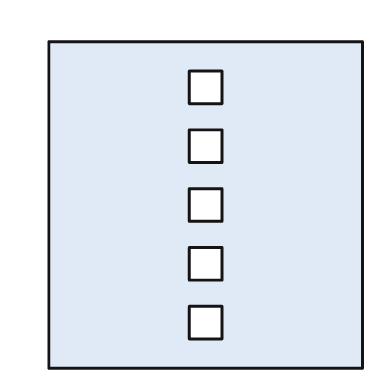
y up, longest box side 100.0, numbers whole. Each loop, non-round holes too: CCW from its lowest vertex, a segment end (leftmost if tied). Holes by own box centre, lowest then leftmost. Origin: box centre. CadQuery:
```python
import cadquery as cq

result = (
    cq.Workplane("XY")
    .moveTo(-48.0, -50.0)
    .lineTo(48.0, -50.0)
    .lineTo(48.0, 50.0)
    .lineTo(-48.0, 50.0)
    .close()
    .moveTo(-5.0, -41.0)
    .lineTo(5.0, -41.0)
    .lineTo(5.0, -31.0)
    .lineTo(-5.0, -31.0)
    .close()
    .moveTo(-5.0, -23.0)
    .lineTo(5.0, -23.0)
    .lineTo(5.0, -13.0)
    .lineTo(-5.0, -13.0)
    .close()
    .moveTo(-5.0, -5.0)
    .lineTo(5.0, -5.0)
    .lineTo(5.0, 5.0)
    .lineTo(-5.0, 5.0)
    .close()
    .moveTo(-5.0, 13.0)
    .lineTo(5.0, 13.0)
    .lineTo(5.0, 23.0)
    .lineTo(-5.0, 23.0)
    .close()
    .moveTo(-5.0, 31.0)
    .lineTo(5.0, 31.0)
    .lineTo(5.0, 41.0)
    .lineTo(-5.0, 41.0)
    .close()
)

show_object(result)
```